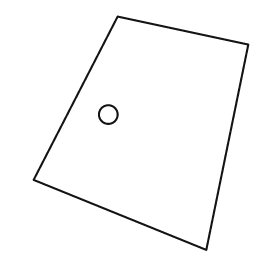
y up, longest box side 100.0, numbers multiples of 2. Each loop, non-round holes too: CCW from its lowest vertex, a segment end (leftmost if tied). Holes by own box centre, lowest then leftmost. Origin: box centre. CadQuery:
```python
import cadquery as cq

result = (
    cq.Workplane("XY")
    .moveTo(28.0, -50.0)
    .lineTo(46.0, 38.0)
    .lineTo(-10.0, 50.0)
    .lineTo(-46.0, -20.0)
    .close()
    .moveTo(-14.0, 8.0)
    .circle(4.0)
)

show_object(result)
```